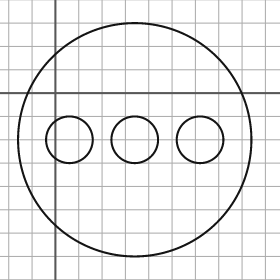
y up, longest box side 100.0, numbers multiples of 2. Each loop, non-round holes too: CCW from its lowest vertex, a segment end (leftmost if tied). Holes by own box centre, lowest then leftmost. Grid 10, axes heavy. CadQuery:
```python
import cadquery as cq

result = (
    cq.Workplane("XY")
    .moveTo(34.0, -20.0)
    .circle(50.0)
    .moveTo(6.0, -20.0)
    .circle(10.0)
    .moveTo(34.0, -20.0)
    .circle(10.0)
    .moveTo(62.0, -20.0)
    .circle(10.0)
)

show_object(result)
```